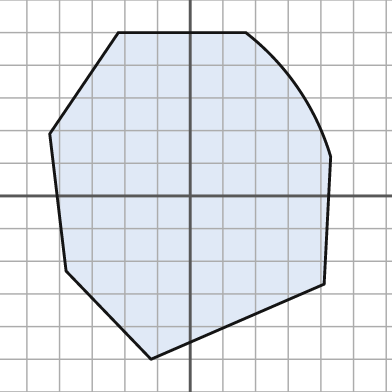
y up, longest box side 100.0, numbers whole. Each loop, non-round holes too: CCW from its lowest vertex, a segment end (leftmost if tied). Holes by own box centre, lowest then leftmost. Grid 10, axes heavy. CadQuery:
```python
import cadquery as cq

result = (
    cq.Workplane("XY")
    .moveTo(-12.0, -50.0)
    .lineTo(41.0, -27.0)
    .lineTo(43.0, 12.0)
    .threePointArc((33.0, 33.0), (17.0, 50.0))
    .lineTo(-22.0, 50.0)
    .lineTo(-43.0, 19.0)
    .lineTo(-38.0, -23.0)
    .close()
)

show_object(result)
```